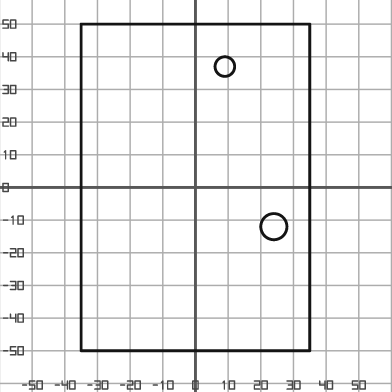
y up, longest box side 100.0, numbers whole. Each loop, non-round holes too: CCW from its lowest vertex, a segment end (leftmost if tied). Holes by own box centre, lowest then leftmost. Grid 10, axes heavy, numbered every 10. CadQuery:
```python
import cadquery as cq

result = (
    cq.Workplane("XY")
    .moveTo(-35.0, -50.0)
    .lineTo(35.0, -50.0)
    .lineTo(35.0, 50.0)
    .lineTo(-35.0, 50.0)
    .close()
    .moveTo(24.0, -12.0)
    .circle(4.0)
    .moveTo(9.0, 37.0)
    .circle(3.0)
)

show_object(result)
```